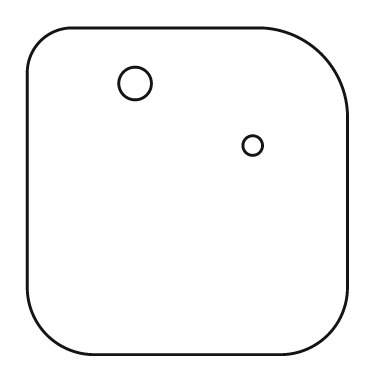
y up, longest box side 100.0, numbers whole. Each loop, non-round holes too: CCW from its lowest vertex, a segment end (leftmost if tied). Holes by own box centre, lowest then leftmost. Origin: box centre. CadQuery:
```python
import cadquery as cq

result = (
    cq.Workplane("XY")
    .moveTo(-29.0, -50.0)
    .lineTo(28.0, -50.0)
    .threePointArc((43.0, -44.0), (49.0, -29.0))
    .lineTo(49.0, 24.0)
    .threePointArc((41.0, 42.0), (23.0, 50.0))
    .lineTo(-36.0, 50.0)
    .threePointArc((-45.0, 46.0), (-49.0, 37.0))
    .lineTo(-49.0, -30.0)
    .threePointArc((-43.0, -44.0), (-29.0, -50.0))
    .close()
    .moveTo(20.0, 14.0)
    .circle(3.0)
    .moveTo(-16.0, 33.0)
    .circle(5.0)
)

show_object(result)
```